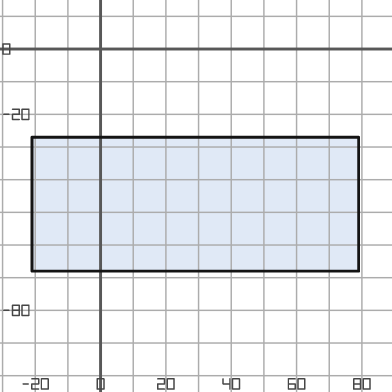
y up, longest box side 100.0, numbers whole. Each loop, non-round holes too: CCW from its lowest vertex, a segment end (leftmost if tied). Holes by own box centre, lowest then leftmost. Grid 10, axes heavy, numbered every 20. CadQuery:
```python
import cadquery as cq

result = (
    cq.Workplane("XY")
    .moveTo(-21.0, -68.0)
    .lineTo(79.0, -68.0)
    .lineTo(79.0, -27.0)
    .lineTo(-21.0, -27.0)
    .close()
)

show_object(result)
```